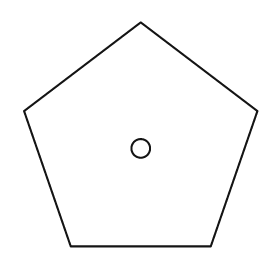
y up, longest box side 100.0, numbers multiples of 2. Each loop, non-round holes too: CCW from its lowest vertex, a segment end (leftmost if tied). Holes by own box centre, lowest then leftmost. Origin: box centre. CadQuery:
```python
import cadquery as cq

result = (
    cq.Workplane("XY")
    .moveTo(-30.0, -48.0)
    .lineTo(30.0, -48.0)
    .lineTo(50.0, 10.0)
    .lineTo(0.0, 48.0)
    .lineTo(-50.0, 10.0)
    .close()
    .moveTo(0.0, -6.0)
    .circle(4.0)
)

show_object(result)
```